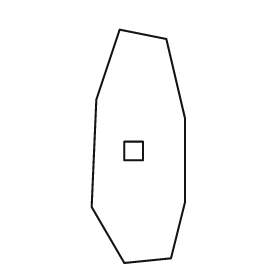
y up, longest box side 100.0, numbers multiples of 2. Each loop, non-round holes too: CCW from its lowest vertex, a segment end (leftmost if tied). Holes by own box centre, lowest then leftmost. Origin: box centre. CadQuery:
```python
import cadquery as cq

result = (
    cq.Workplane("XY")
    .moveTo(-6.0, -50.0)
    .lineTo(14.0, -48.0)
    .lineTo(20.0, -24.0)
    .lineTo(20.0, 12.0)
    .lineTo(12.0, 46.0)
    .lineTo(-8.0, 50.0)
    .lineTo(-18.0, 20.0)
    .lineTo(-20.0, -26.0)
    .close()
    .moveTo(-6.0, -6.0)
    .lineTo(2.0, -6.0)
    .lineTo(2.0, 2.0)
    .lineTo(-6.0, 2.0)
    .close()
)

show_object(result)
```